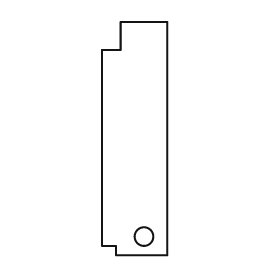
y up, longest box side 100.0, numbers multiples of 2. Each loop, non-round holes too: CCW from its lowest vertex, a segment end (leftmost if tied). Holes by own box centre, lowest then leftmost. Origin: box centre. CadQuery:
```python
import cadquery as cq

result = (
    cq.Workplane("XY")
    .moveTo(-8.0, -50.0)
    .lineTo(14.0, -50.0)
    .lineTo(14.0, 50.0)
    .lineTo(-6.0, 50.0)
    .lineTo(-6.0, 38.0)
    .lineTo(-14.0, 38.0)
    .lineTo(-14.0, -46.0)
    .lineTo(-8.0, -46.0)
    .close()
    .moveTo(4.0, -42.0)
    .circle(4.0)
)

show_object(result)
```